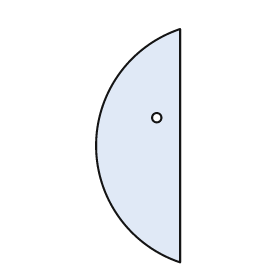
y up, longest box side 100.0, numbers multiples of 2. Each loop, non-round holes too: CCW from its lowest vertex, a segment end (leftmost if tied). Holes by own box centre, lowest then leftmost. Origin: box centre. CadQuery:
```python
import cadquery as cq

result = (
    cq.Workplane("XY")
    .moveTo(18.0, -50.0)
    .lineTo(18.0, 50.0)
    .threePointArc((-18.0, 0.0), (18.0, -50.0))
    .close()
    .moveTo(8.0, 12.0)
    .circle(2.0)
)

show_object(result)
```